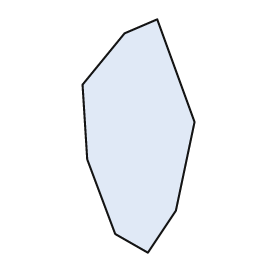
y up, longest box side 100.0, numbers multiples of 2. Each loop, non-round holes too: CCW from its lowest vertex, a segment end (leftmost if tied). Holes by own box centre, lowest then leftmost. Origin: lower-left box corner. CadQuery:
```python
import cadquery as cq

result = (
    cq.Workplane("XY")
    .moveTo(28.0, 0.0)
    .lineTo(40.0, 18.0)
    .lineTo(48.0, 56.0)
    .lineTo(32.0, 100.0)
    .lineTo(18.0, 94.0)
    .lineTo(0.0, 72.0)
    .lineTo(2.0, 40.0)
    .lineTo(14.0, 8.0)
    .close()
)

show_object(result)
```